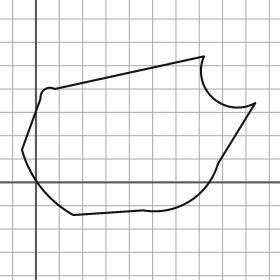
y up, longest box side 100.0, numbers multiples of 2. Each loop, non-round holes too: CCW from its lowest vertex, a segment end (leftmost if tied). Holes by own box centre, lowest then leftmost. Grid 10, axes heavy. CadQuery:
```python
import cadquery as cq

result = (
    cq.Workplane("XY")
    .moveTo(16.0, -14.0)
    .lineTo(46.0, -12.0)
    .threePointArc((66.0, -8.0), (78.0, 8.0))
    .lineTo(94.0, 34.0)
    .threePointArc((76.0, 36.0), (72.0, 54.0))
    .lineTo(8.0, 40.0)
    .threePointArc((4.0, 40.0), (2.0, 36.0))
    .lineTo(-6.0, 14.0)
    .threePointArc((2.0, -2.0), (16.0, -14.0))
    .close()
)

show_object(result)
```